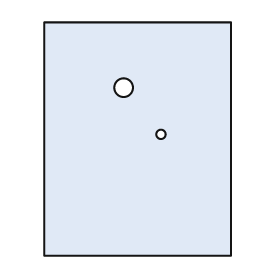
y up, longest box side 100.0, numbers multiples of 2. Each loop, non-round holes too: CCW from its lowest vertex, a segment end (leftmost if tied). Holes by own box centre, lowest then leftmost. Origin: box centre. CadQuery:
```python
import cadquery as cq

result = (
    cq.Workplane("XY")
    .moveTo(-40.0, -50.0)
    .lineTo(40.0, -50.0)
    .lineTo(40.0, 50.0)
    .lineTo(-40.0, 50.0)
    .close()
    .moveTo(10.0, 2.0)
    .circle(2.0)
    .moveTo(-6.0, 22.0)
    .circle(4.0)
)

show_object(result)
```